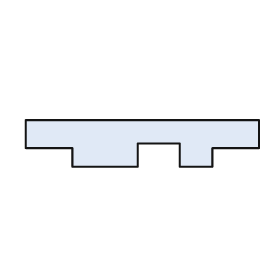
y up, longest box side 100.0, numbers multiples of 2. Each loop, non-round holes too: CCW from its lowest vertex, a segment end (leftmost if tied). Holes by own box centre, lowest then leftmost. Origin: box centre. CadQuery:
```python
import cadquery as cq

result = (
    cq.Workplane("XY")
    .moveTo(-30.0, -10.0)
    .lineTo(-2.0, -10.0)
    .lineTo(-2.0, 0.0)
    .lineTo(16.0, 0.0)
    .lineTo(16.0, -10.0)
    .lineTo(30.0, -10.0)
    .lineTo(30.0, -2.0)
    .lineTo(50.0, -2.0)
    .lineTo(50.0, 10.0)
    .lineTo(-50.0, 10.0)
    .lineTo(-50.0, -2.0)
    .lineTo(-30.0, -2.0)
    .close()
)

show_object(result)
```